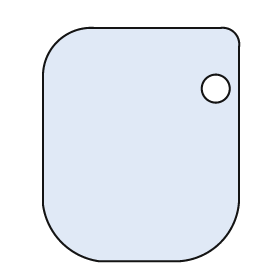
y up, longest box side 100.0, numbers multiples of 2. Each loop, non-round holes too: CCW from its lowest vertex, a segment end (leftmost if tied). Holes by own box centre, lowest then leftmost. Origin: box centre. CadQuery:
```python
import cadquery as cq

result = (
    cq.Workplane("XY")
    .moveTo(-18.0, -50.0)
    .lineTo(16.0, -50.0)
    .threePointArc((34.0, -42.0), (42.0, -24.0))
    .lineTo(42.0, 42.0)
    .threePointArc((40.0, 48.0), (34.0, 50.0))
    .lineTo(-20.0, 50.0)
    .threePointArc((-36.0, 44.0), (-42.0, 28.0))
    .lineTo(-42.0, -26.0)
    .threePointArc((-34.0, -42.0), (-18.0, -50.0))
    .close()
    .moveTo(32.0, 24.0)
    .circle(6.0)
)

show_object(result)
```